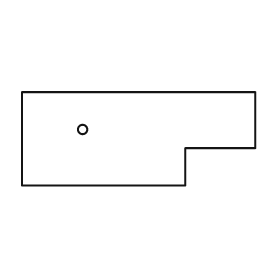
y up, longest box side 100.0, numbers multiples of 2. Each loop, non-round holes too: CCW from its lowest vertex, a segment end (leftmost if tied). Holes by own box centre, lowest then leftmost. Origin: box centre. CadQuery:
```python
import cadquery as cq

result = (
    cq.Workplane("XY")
    .moveTo(-50.0, -20.0)
    .lineTo(20.0, -20.0)
    .lineTo(20.0, -4.0)
    .lineTo(50.0, -4.0)
    .lineTo(50.0, 20.0)
    .lineTo(-50.0, 20.0)
    .close()
    .moveTo(-24.0, 4.0)
    .circle(2.0)
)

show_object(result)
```